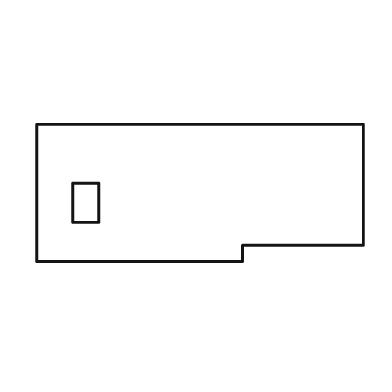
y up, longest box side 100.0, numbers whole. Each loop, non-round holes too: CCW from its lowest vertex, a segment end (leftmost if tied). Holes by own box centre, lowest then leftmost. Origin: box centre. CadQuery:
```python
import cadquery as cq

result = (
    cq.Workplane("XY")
    .moveTo(-50.0, -21.0)
    .lineTo(13.0, -21.0)
    .lineTo(13.0, -16.0)
    .lineTo(50.0, -16.0)
    .lineTo(50.0, 21.0)
    .lineTo(-50.0, 21.0)
    .close()
    .moveTo(-39.0, -9.0)
    .lineTo(-31.0, -9.0)
    .lineTo(-31.0, 3.0)
    .lineTo(-39.0, 3.0)
    .close()
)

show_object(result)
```